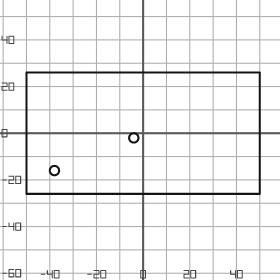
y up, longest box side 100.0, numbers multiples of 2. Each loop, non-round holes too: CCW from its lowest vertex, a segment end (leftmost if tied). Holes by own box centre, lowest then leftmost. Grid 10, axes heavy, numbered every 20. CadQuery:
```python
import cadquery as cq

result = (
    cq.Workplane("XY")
    .moveTo(-50.0, -26.0)
    .lineTo(50.0, -26.0)
    .lineTo(50.0, 26.0)
    .lineTo(-50.0, 26.0)
    .close()
    .moveTo(-38.0, -16.0)
    .circle(2.0)
    .moveTo(-4.0, -2.0)
    .circle(2.0)
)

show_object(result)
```